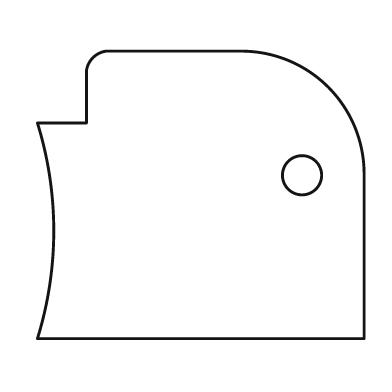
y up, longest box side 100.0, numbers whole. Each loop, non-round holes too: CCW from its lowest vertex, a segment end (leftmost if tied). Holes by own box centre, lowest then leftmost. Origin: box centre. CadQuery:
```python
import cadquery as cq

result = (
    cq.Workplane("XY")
    .moveTo(-50.0, -44.0)
    .lineTo(50.0, -44.0)
    .lineTo(50.0, 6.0)
    .threePointArc((39.0, 33.0), (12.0, 44.0))
    .lineTo(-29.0, 44.0)
    .threePointArc((-33.0, 42.0), (-35.0, 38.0))
    .lineTo(-35.0, 22.0)
    .lineTo(-50.0, 22.0)
    .threePointArc((-45.0, -11.0), (-50.0, -44.0))
    .close()
    .moveTo(31.0, 6.0)
    .circle(6.0)
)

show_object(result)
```